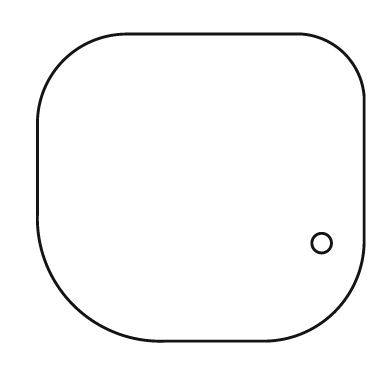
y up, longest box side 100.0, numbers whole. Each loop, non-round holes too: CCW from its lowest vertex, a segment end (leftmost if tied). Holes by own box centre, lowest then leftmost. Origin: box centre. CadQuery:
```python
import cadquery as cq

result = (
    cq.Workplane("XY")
    .moveTo(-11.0, -47.0)
    .lineTo(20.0, -47.0)
    .threePointArc((41.0, -38.0), (50.0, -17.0))
    .lineTo(50.0, 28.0)
    .threePointArc((44.0, 41.0), (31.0, 47.0))
    .lineTo(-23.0, 47.0)
    .threePointArc((-42.0, 39.0), (-50.0, 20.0))
    .lineTo(-50.0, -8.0)
    .threePointArc((-39.0, -36.0), (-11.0, -47.0))
    .close()
    .moveTo(37.0, -17.0)
    .circle(3.0)
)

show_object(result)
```